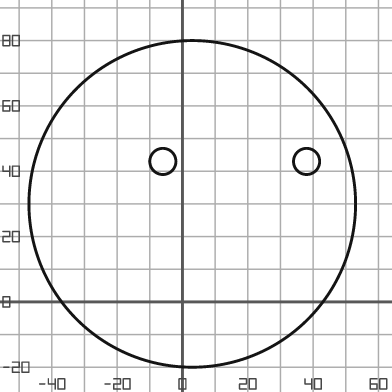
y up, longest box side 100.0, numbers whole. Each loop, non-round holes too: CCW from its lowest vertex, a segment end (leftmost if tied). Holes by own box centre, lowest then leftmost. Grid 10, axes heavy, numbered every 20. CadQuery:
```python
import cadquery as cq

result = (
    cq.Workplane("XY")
    .moveTo(3.0, 30.0)
    .circle(50.0)
    .moveTo(-6.0, 43.0)
    .circle(4.0)
    .moveTo(38.0, 43.0)
    .circle(4.0)
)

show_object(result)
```